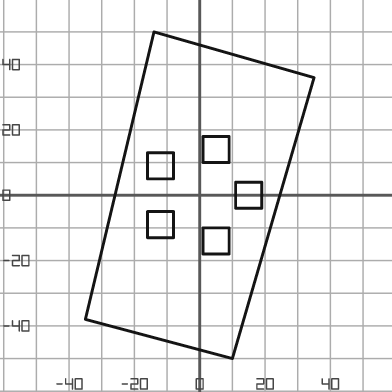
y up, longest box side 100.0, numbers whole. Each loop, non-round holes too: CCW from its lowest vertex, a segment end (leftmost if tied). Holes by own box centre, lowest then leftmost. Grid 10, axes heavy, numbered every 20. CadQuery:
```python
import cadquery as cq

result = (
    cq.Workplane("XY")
    .moveTo(10.0, -50.0)
    .lineTo(35.0, 36.0)
    .lineTo(-14.0, 50.0)
    .lineTo(-35.0, -38.0)
    .close()
    .moveTo(1.0, -18.0)
    .lineTo(9.0, -18.0)
    .lineTo(9.0, -10.0)
    .lineTo(1.0, -10.0)
    .close()
    .moveTo(-16.0, -13.0)
    .lineTo(-8.0, -13.0)
    .lineTo(-8.0, -5.0)
    .lineTo(-16.0, -5.0)
    .close()
    .moveTo(11.0, -4.0)
    .lineTo(19.0, -4.0)
    .lineTo(19.0, 4.0)
    .lineTo(11.0, 4.0)
    .close()
    .moveTo(-16.0, 5.0)
    .lineTo(-8.0, 5.0)
    .lineTo(-8.0, 13.0)
    .lineTo(-16.0, 13.0)
    .close()
    .moveTo(1.0, 10.0)
    .lineTo(9.0, 10.0)
    .lineTo(9.0, 18.0)
    .lineTo(1.0, 18.0)
    .close()
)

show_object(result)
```